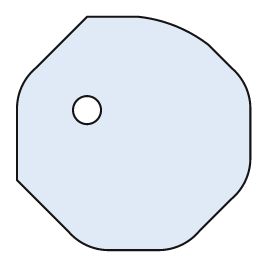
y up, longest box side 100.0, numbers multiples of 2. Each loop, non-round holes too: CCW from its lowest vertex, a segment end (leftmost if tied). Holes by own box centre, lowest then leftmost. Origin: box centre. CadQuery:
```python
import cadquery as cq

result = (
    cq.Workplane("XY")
    .moveTo(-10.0, -50.0)
    .lineTo(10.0, -50.0)
    .threePointArc((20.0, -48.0), (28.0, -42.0))
    .lineTo(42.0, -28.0)
    .threePointArc((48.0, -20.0), (50.0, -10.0))
    .lineTo(50.0, 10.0)
    .threePointArc((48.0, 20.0), (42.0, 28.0))
    .lineTo(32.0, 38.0)
    .threePointArc((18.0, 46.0), (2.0, 50.0))
    .lineTo(-20.0, 50.0)
    .lineTo(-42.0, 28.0)
    .threePointArc((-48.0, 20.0), (-50.0, 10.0))
    .lineTo(-50.0, -20.0)
    .lineTo(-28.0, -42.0)
    .threePointArc((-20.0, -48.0), (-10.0, -50.0))
    .close()
    .moveTo(-20.0, 10.0)
    .circle(6.0)
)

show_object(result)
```